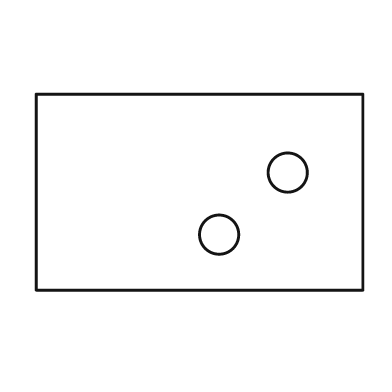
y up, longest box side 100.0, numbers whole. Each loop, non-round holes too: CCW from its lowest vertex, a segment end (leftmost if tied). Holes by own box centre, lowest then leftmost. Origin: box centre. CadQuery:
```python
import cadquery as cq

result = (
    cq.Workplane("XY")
    .moveTo(-50.0, -30.0)
    .lineTo(50.0, -30.0)
    .lineTo(50.0, 30.0)
    .lineTo(-50.0, 30.0)
    .close()
    .moveTo(6.0, -13.0)
    .circle(6.0)
    .moveTo(27.0, 6.0)
    .circle(6.0)
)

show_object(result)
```